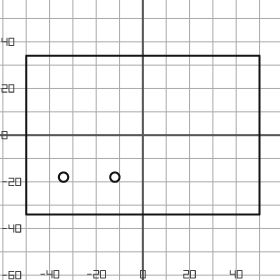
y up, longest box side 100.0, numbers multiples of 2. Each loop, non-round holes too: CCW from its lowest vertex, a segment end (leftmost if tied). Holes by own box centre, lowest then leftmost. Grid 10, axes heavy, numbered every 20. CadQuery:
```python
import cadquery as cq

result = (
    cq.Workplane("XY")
    .moveTo(-50.0, -34.0)
    .lineTo(50.0, -34.0)
    .lineTo(50.0, 34.0)
    .lineTo(-50.0, 34.0)
    .close()
    .moveTo(-34.0, -18.0)
    .circle(2.0)
    .moveTo(-12.0, -18.0)
    .circle(2.0)
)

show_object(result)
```